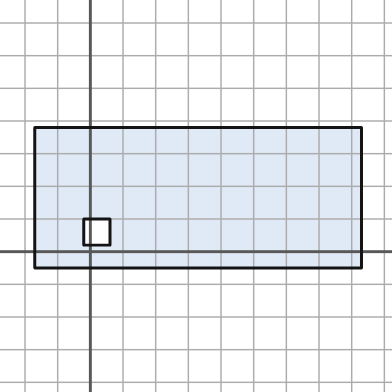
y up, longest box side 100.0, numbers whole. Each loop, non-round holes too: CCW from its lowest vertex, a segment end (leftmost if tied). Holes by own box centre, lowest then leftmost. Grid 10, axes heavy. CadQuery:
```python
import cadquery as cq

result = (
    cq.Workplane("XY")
    .moveTo(-17.0, -5.0)
    .lineTo(83.0, -5.0)
    .lineTo(83.0, 38.0)
    .lineTo(-17.0, 38.0)
    .close()
    .moveTo(-2.0, 2.0)
    .lineTo(6.0, 2.0)
    .lineTo(6.0, 10.0)
    .lineTo(-2.0, 10.0)
    .close()
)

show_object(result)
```